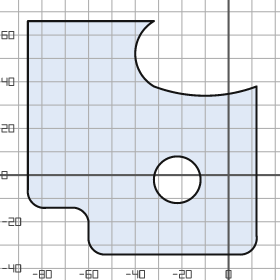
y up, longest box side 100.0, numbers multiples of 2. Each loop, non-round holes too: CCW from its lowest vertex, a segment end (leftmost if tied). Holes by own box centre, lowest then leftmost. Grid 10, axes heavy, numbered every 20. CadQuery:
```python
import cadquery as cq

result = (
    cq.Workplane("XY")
    .moveTo(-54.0, -34.0)
    .lineTo(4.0, -34.0)
    .threePointArc((10.0, -32.0), (12.0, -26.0))
    .lineTo(12.0, 38.0)
    .threePointArc((-10.0, 34.0), (-32.0, 38.0))
    .threePointArc((-40.0, 52.0), (-32.0, 66.0))
    .lineTo(-86.0, 66.0)
    .lineTo(-86.0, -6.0)
    .threePointArc((-84.0, -12.0), (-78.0, -14.0))
    .lineTo(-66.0, -14.0)
    .threePointArc((-62.0, -16.0), (-60.0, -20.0))
    .lineTo(-60.0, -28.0)
    .threePointArc((-58.0, -32.0), (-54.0, -34.0))
    .close()
    .moveTo(-22.0, -2.0)
    .circle(10.0)
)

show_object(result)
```